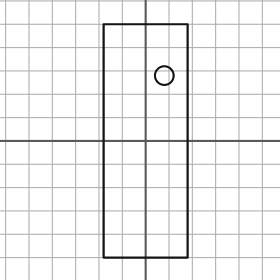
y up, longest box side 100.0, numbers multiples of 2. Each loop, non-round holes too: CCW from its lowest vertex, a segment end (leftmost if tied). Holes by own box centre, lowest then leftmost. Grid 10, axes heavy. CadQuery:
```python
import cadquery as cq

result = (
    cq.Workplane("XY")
    .moveTo(-18.0, -50.0)
    .lineTo(18.0, -50.0)
    .lineTo(18.0, 50.0)
    .lineTo(-18.0, 50.0)
    .close()
    .moveTo(8.0, 28.0)
    .circle(4.0)
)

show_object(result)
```